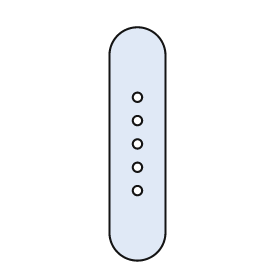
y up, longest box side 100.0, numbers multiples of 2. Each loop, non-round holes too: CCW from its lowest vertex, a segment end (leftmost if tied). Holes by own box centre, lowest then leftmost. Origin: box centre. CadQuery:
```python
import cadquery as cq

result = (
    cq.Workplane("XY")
    .moveTo(-12.0, -38.0)
    .threePointArc((0.0, -50.0), (12.0, -38.0))
    .lineTo(12.0, 38.0)
    .threePointArc((0.0, 50.0), (-12.0, 38.0))
    .close()
    .moveTo(0.0, -20.0)
    .circle(2.0)
    .moveTo(0.0, -10.0)
    .circle(2.0)
    .moveTo(0.0, 0.0)
    .circle(2.0)
    .moveTo(0.0, 10.0)
    .circle(2.0)
    .moveTo(0.0, 20.0)
    .circle(2.0)
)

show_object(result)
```